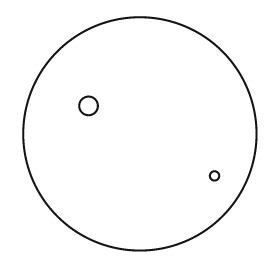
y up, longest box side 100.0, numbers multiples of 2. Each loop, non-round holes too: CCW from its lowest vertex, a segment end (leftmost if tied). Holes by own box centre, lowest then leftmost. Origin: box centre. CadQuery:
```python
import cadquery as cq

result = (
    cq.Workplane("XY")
    .moveTo(0.0, 0.0)
    .circle(50.0)
    .moveTo(32.0, -18.0)
    .circle(2.0)
    .moveTo(-22.0, 12.0)
    .circle(4.0)
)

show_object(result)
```